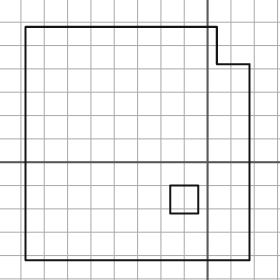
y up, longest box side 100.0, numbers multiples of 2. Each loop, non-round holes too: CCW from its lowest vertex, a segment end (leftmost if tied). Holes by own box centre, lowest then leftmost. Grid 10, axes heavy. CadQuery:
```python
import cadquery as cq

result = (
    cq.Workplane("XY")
    .moveTo(-78.0, -42.0)
    .lineTo(18.0, -42.0)
    .lineTo(18.0, 42.0)
    .lineTo(4.0, 42.0)
    .lineTo(4.0, 58.0)
    .lineTo(-78.0, 58.0)
    .close()
    .moveTo(-16.0, -22.0)
    .lineTo(-4.0, -22.0)
    .lineTo(-4.0, -10.0)
    .lineTo(-16.0, -10.0)
    .close()
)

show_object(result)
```